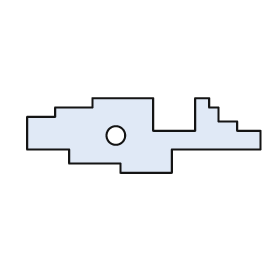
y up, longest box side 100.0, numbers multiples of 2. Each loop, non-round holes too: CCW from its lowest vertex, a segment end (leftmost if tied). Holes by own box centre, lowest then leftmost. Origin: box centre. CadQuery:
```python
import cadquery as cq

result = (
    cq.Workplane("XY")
    .moveTo(-10.0, -16.0)
    .lineTo(12.0, -16.0)
    .lineTo(12.0, -6.0)
    .lineTo(50.0, -6.0)
    .lineTo(50.0, 2.0)
    .lineTo(40.0, 2.0)
    .lineTo(40.0, 6.0)
    .lineTo(32.0, 6.0)
    .lineTo(32.0, 12.0)
    .lineTo(28.0, 12.0)
    .lineTo(28.0, 16.0)
    .lineTo(22.0, 16.0)
    .lineTo(22.0, 2.0)
    .lineTo(4.0, 2.0)
    .lineTo(4.0, 16.0)
    .lineTo(-22.0, 16.0)
    .lineTo(-22.0, 12.0)
    .lineTo(-38.0, 12.0)
    .lineTo(-38.0, 8.0)
    .lineTo(-50.0, 8.0)
    .lineTo(-50.0, -6.0)
    .lineTo(-32.0, -6.0)
    .lineTo(-32.0, -12.0)
    .lineTo(-10.0, -12.0)
    .close()
    .moveTo(-12.0, 0.0)
    .circle(4.0)
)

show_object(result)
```